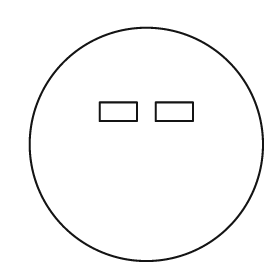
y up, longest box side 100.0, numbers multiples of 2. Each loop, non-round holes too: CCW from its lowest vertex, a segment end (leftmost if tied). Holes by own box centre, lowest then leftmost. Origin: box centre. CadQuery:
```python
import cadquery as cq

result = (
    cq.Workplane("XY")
    .moveTo(0.0, 0.0)
    .circle(50.0)
    .moveTo(-20.0, 10.0)
    .lineTo(-4.0, 10.0)
    .lineTo(-4.0, 18.0)
    .lineTo(-20.0, 18.0)
    .close()
    .moveTo(4.0, 10.0)
    .lineTo(20.0, 10.0)
    .lineTo(20.0, 18.0)
    .lineTo(4.0, 18.0)
    .close()
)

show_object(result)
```